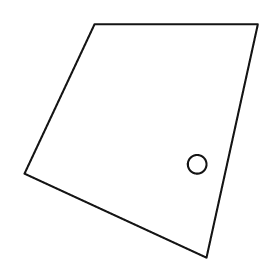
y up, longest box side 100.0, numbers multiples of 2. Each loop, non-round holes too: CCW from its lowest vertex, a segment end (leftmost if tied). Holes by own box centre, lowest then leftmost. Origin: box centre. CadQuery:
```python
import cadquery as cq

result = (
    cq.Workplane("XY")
    .moveTo(28.0, -50.0)
    .lineTo(50.0, 50.0)
    .lineTo(-20.0, 50.0)
    .lineTo(-50.0, -14.0)
    .close()
    .moveTo(24.0, -10.0)
    .circle(4.0)
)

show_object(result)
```